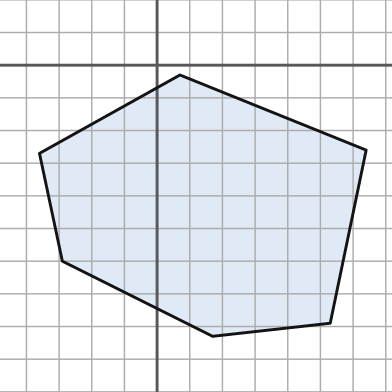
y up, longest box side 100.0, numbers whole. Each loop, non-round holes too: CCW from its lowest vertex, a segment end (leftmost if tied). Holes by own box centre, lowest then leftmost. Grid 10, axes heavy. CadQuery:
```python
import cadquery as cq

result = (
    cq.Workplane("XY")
    .moveTo(17.0, -83.0)
    .lineTo(53.0, -79.0)
    .lineTo(64.0, -26.0)
    .lineTo(7.0, -3.0)
    .lineTo(-36.0, -27.0)
    .lineTo(-29.0, -60.0)
    .close()
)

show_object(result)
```